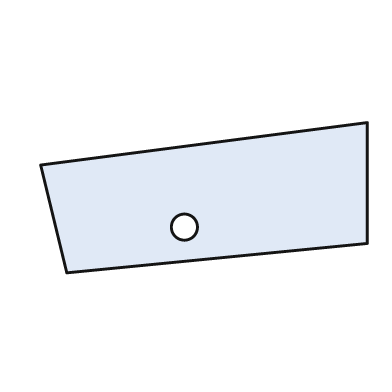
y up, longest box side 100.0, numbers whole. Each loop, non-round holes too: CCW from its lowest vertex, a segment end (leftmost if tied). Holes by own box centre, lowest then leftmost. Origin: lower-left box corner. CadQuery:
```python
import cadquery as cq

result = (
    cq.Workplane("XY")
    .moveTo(8.0, 0.0)
    .lineTo(100.0, 9.0)
    .lineTo(100.0, 46.0)
    .lineTo(0.0, 33.0)
    .close()
    .moveTo(44.0, 14.0)
    .circle(4.0)
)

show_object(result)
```